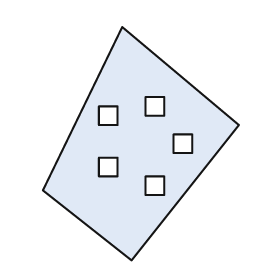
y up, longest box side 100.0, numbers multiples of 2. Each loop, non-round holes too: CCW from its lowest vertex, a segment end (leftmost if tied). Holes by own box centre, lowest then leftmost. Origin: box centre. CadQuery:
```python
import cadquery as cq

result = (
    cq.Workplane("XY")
    .moveTo(-4.0, -50.0)
    .lineTo(42.0, 8.0)
    .lineTo(-8.0, 50.0)
    .lineTo(-42.0, -20.0)
    .close()
    .moveTo(2.0, -22.0)
    .lineTo(10.0, -22.0)
    .lineTo(10.0, -14.0)
    .lineTo(2.0, -14.0)
    .close()
    .moveTo(-18.0, -14.0)
    .lineTo(-10.0, -14.0)
    .lineTo(-10.0, -6.0)
    .lineTo(-18.0, -6.0)
    .close()
    .moveTo(14.0, -4.0)
    .lineTo(22.0, -4.0)
    .lineTo(22.0, 4.0)
    .lineTo(14.0, 4.0)
    .close()
    .moveTo(-18.0, 8.0)
    .lineTo(-10.0, 8.0)
    .lineTo(-10.0, 16.0)
    .lineTo(-18.0, 16.0)
    .close()
    .moveTo(2.0, 12.0)
    .lineTo(10.0, 12.0)
    .lineTo(10.0, 20.0)
    .lineTo(2.0, 20.0)
    .close()
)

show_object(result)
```